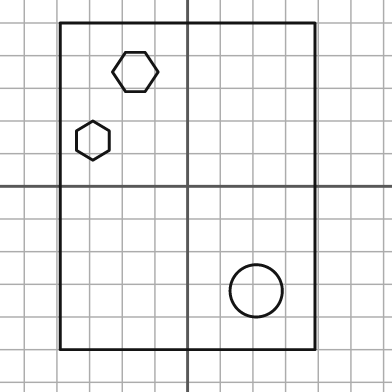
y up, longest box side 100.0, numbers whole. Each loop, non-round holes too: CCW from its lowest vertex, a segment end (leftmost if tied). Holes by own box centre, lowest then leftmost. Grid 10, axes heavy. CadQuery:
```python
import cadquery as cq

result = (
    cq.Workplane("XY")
    .moveTo(-39.0, -50.0)
    .lineTo(39.0, -50.0)
    .lineTo(39.0, 50.0)
    .lineTo(-39.0, 50.0)
    .close()
    .moveTo(21.0, -32.0)
    .circle(8.0)
    .moveTo(-29.0, 8.0)
    .lineTo(-24.0, 11.0)
    .lineTo(-24.0, 17.0)
    .lineTo(-29.0, 20.0)
    .lineTo(-34.0, 17.0)
    .lineTo(-34.0, 11.0)
    .close()
    .moveTo(-19.0, 29.0)
    .lineTo(-13.0, 29.0)
    .lineTo(-9.0, 35.0)
    .lineTo(-13.0, 41.0)
    .lineTo(-19.0, 41.0)
    .lineTo(-23.0, 35.0)
    .close()
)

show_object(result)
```